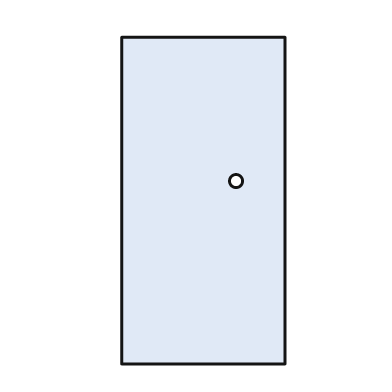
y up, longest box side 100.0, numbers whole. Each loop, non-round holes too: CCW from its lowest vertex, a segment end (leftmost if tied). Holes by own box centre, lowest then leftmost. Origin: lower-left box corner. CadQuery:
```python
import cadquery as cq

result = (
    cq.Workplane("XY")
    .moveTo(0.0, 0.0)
    .lineTo(50.0, 0.0)
    .lineTo(50.0, 100.0)
    .lineTo(0.0, 100.0)
    .close()
    .moveTo(35.0, 56.0)
    .circle(2.0)
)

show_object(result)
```